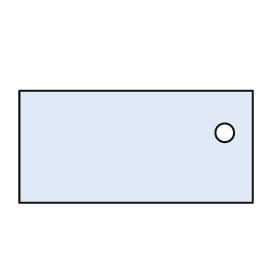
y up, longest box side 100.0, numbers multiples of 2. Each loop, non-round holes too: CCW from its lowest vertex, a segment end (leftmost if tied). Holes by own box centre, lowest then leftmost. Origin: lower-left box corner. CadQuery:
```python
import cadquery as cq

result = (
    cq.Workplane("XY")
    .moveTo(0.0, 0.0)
    .lineTo(100.0, 0.0)
    .lineTo(100.0, 48.0)
    .lineTo(0.0, 48.0)
    .close()
    .moveTo(88.0, 30.0)
    .circle(4.0)
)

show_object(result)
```